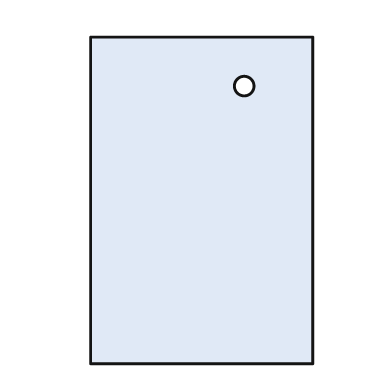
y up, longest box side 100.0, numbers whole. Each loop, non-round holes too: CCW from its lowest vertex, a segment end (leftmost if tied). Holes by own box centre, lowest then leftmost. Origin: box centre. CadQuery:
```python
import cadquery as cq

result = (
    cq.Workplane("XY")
    .moveTo(-34.0, -50.0)
    .lineTo(34.0, -50.0)
    .lineTo(34.0, 50.0)
    .lineTo(-34.0, 50.0)
    .close()
    .moveTo(13.0, 35.0)
    .circle(3.0)
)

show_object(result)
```